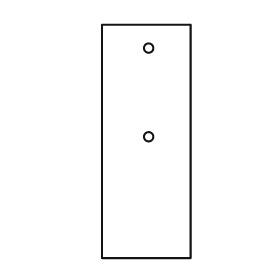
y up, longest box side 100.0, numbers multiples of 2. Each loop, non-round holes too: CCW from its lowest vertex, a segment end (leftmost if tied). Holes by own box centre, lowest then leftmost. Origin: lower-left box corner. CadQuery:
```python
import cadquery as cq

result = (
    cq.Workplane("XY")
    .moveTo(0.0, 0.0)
    .lineTo(38.0, 0.0)
    .lineTo(38.0, 100.0)
    .lineTo(0.0, 100.0)
    .close()
    .moveTo(20.0, 52.0)
    .circle(2.0)
    .moveTo(20.0, 90.0)
    .circle(2.0)
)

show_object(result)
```